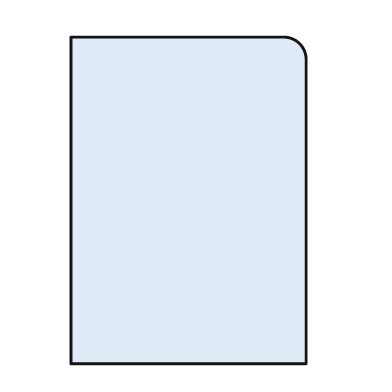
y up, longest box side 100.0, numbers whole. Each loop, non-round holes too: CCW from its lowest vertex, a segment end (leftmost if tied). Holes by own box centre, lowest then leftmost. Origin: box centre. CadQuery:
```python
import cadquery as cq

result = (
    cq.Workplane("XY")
    .moveTo(-36.0, -50.0)
    .lineTo(36.0, -50.0)
    .lineTo(36.0, 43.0)
    .threePointArc((34.0, 48.0), (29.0, 50.0))
    .lineTo(-36.0, 50.0)
    .close()
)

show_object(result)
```